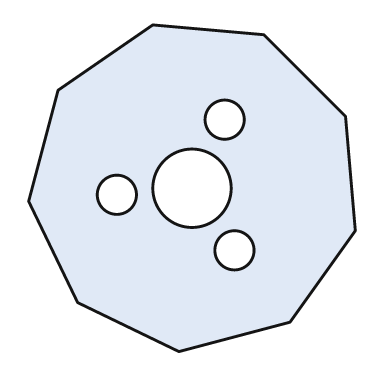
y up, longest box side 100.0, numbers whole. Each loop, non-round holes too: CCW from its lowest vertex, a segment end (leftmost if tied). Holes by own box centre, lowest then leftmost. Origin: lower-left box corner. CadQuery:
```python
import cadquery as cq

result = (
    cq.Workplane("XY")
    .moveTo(46.0, 0.0)
    .lineTo(80.0, 9.0)
    .lineTo(100.0, 37.0)
    .lineTo(97.0, 72.0)
    .lineTo(72.0, 97.0)
    .lineTo(38.0, 100.0)
    .lineTo(9.0, 80.0)
    .lineTo(0.0, 46.0)
    .lineTo(15.0, 15.0)
    .close()
    .moveTo(63.0, 31.0)
    .circle(6.0)
    .moveTo(27.0, 48.0)
    .circle(6.0)
    .moveTo(50.0, 50.0)
    .circle(12.0)
    .moveTo(60.0, 71.0)
    .circle(6.0)
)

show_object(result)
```